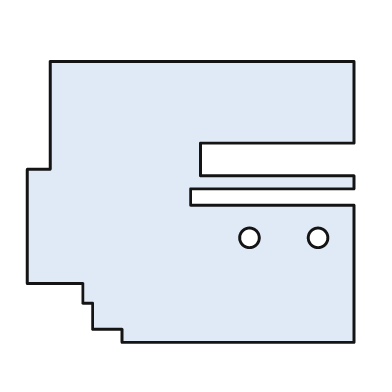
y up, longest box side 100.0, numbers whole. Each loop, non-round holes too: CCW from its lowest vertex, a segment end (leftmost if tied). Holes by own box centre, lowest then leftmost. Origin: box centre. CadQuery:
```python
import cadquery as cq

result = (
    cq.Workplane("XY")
    .moveTo(-21.0, -43.0)
    .lineTo(50.0, -43.0)
    .lineTo(50.0, -1.0)
    .lineTo(0.0, -1.0)
    .lineTo(0.0, 4.0)
    .lineTo(50.0, 4.0)
    .lineTo(50.0, 8.0)
    .lineTo(3.0, 8.0)
    .lineTo(3.0, 18.0)
    .lineTo(50.0, 18.0)
    .lineTo(50.0, 43.0)
    .lineTo(-43.0, 43.0)
    .lineTo(-43.0, 10.0)
    .lineTo(-50.0, 10.0)
    .lineTo(-50.0, -25.0)
    .lineTo(-33.0, -25.0)
    .lineTo(-33.0, -31.0)
    .lineTo(-30.0, -31.0)
    .lineTo(-30.0, -39.0)
    .lineTo(-21.0, -39.0)
    .close()
    .moveTo(18.0, -11.0)
    .circle(3.0)
    .moveTo(39.0, -11.0)
    .circle(3.0)
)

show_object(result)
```